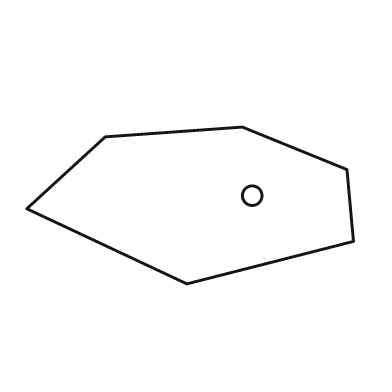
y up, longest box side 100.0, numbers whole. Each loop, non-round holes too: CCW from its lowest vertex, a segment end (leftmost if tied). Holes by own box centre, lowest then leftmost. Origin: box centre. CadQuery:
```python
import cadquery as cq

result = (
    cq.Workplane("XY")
    .moveTo(-1.0, -24.0)
    .lineTo(50.0, -11.0)
    .lineTo(48.0, 11.0)
    .lineTo(16.0, 24.0)
    .lineTo(-26.0, 21.0)
    .lineTo(-50.0, -1.0)
    .close()
    .moveTo(19.0, 3.0)
    .circle(3.0)
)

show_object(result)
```